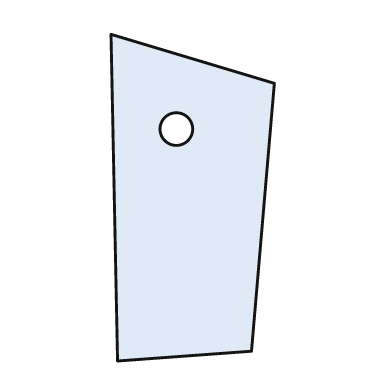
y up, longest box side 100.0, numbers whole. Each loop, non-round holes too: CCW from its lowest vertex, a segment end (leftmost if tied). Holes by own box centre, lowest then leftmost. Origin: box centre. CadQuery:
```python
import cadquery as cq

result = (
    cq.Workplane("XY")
    .moveTo(-23.0, -50.0)
    .lineTo(18.0, -47.0)
    .lineTo(25.0, 35.0)
    .lineTo(-25.0, 50.0)
    .close()
    .moveTo(-5.0, 21.0)
    .circle(5.0)
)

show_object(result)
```